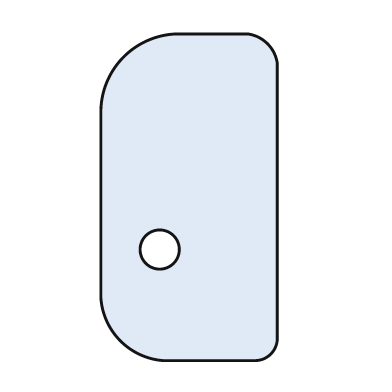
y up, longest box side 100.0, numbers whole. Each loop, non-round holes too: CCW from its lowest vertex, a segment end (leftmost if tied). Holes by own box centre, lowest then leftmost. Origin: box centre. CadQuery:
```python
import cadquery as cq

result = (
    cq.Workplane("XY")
    .moveTo(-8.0, -50.0)
    .lineTo(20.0, -50.0)
    .threePointArc((25.0, -48.0), (27.0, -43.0))
    .lineTo(27.0, 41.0)
    .threePointArc((24.0, 47.0), (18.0, 50.0))
    .lineTo(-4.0, 50.0)
    .threePointArc((-20.0, 43.0), (-27.0, 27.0))
    .lineTo(-27.0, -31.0)
    .threePointArc((-21.0, -44.0), (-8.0, -50.0))
    .close()
    .moveTo(-9.0, -16.0)
    .circle(6.0)
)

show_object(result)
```